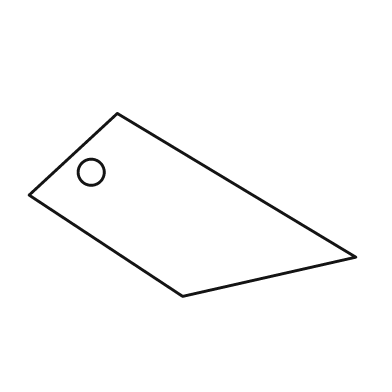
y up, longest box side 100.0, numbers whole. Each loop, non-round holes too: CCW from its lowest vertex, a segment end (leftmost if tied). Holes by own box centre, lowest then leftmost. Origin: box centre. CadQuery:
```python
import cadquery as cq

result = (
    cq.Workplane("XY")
    .moveTo(-3.0, -28.0)
    .lineTo(50.0, -16.0)
    .lineTo(-23.0, 28.0)
    .lineTo(-50.0, 3.0)
    .close()
    .moveTo(-31.0, 10.0)
    .circle(4.0)
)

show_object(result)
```